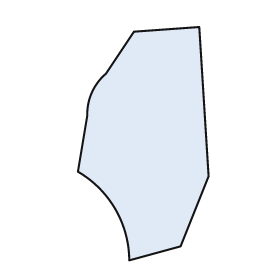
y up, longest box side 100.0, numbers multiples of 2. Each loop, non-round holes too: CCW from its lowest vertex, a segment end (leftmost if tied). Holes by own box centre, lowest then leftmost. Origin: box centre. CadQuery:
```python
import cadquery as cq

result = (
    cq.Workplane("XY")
    .moveTo(-6.0, -50.0)
    .lineTo(16.0, -44.0)
    .lineTo(28.0, -14.0)
    .lineTo(24.0, 50.0)
    .lineTo(-4.0, 48.0)
    .lineTo(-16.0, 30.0)
    .threePointArc((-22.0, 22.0), (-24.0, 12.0))
    .lineTo(-28.0, -12.0)
    .threePointArc((-12.0, -28.0), (-6.0, -50.0))
    .close()
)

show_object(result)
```